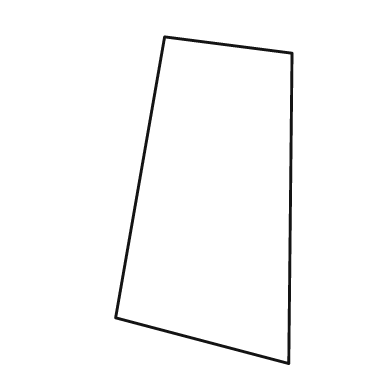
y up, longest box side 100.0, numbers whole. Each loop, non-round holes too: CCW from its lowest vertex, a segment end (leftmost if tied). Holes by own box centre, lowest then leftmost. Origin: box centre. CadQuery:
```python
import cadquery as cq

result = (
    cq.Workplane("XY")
    .moveTo(26.0, -50.0)
    .lineTo(27.0, 45.0)
    .lineTo(-12.0, 50.0)
    .lineTo(-27.0, -36.0)
    .close()
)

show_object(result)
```